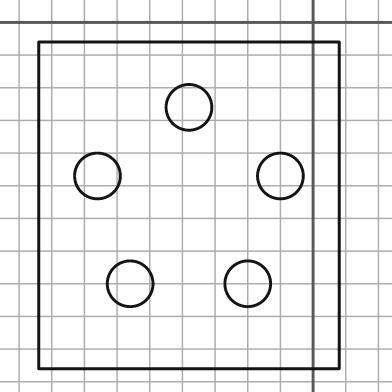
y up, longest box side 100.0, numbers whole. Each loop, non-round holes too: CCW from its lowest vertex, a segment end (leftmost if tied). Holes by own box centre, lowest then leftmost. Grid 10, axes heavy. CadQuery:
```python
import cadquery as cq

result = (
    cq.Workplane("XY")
    .moveTo(-84.0, -106.0)
    .lineTo(8.0, -106.0)
    .lineTo(8.0, -6.0)
    .lineTo(-84.0, -6.0)
    .close()
    .moveTo(-56.0, -80.0)
    .circle(7.0)
    .moveTo(-20.0, -80.0)
    .circle(7.0)
    .moveTo(-66.0, -47.0)
    .circle(7.0)
    .moveTo(-10.0, -47.0)
    .circle(7.0)
    .moveTo(-38.0, -26.0)
    .circle(7.0)
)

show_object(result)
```